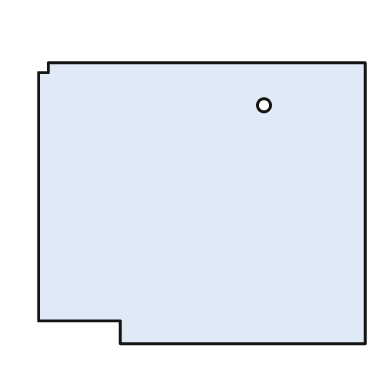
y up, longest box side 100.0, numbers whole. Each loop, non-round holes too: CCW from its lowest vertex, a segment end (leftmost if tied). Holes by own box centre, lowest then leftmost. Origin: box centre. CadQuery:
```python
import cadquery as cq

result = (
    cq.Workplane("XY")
    .moveTo(-25.0, -43.0)
    .lineTo(50.0, -43.0)
    .lineTo(50.0, 43.0)
    .lineTo(-47.0, 43.0)
    .lineTo(-47.0, 40.0)
    .lineTo(-50.0, 40.0)
    .lineTo(-50.0, -36.0)
    .lineTo(-25.0, -36.0)
    .close()
    .moveTo(19.0, 30.0)
    .circle(2.0)
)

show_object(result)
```